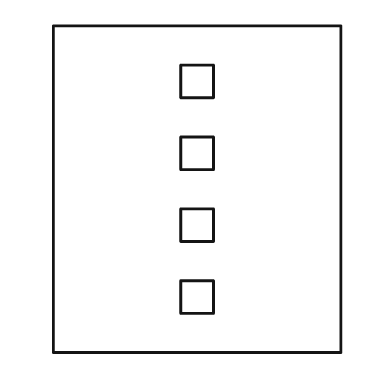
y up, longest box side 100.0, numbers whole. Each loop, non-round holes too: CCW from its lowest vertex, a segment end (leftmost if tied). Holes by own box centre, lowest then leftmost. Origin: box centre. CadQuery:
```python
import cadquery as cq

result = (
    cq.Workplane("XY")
    .moveTo(-44.0, -50.0)
    .lineTo(44.0, -50.0)
    .lineTo(44.0, 50.0)
    .lineTo(-44.0, 50.0)
    .close()
    .moveTo(-5.0, -38.0)
    .lineTo(5.0, -38.0)
    .lineTo(5.0, -28.0)
    .lineTo(-5.0, -28.0)
    .close()
    .moveTo(-5.0, -16.0)
    .lineTo(5.0, -16.0)
    .lineTo(5.0, -6.0)
    .lineTo(-5.0, -6.0)
    .close()
    .moveTo(-5.0, 6.0)
    .lineTo(5.0, 6.0)
    .lineTo(5.0, 16.0)
    .lineTo(-5.0, 16.0)
    .close()
    .moveTo(-5.0, 28.0)
    .lineTo(5.0, 28.0)
    .lineTo(5.0, 38.0)
    .lineTo(-5.0, 38.0)
    .close()
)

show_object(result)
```